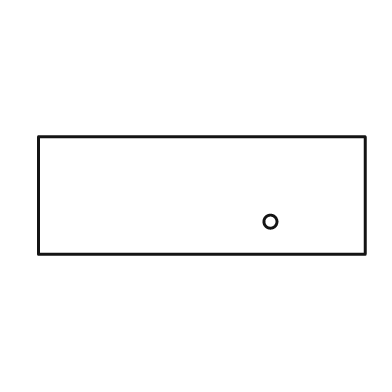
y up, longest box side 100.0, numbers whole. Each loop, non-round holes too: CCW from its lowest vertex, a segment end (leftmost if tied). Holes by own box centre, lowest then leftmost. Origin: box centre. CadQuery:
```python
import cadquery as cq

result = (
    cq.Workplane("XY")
    .moveTo(-50.0, -18.0)
    .lineTo(50.0, -18.0)
    .lineTo(50.0, 18.0)
    .lineTo(-50.0, 18.0)
    .close()
    .moveTo(21.0, -8.0)
    .circle(2.0)
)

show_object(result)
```